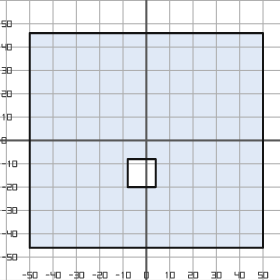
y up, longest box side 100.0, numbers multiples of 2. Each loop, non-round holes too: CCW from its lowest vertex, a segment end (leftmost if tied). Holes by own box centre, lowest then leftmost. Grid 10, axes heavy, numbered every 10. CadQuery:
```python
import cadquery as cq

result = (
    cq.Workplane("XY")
    .moveTo(-50.0, -46.0)
    .lineTo(50.0, -46.0)
    .lineTo(50.0, 46.0)
    .lineTo(-50.0, 46.0)
    .close()
    .moveTo(-8.0, -20.0)
    .lineTo(4.0, -20.0)
    .lineTo(4.0, -8.0)
    .lineTo(-8.0, -8.0)
    .close()
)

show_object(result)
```